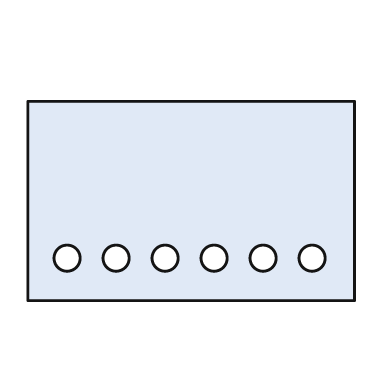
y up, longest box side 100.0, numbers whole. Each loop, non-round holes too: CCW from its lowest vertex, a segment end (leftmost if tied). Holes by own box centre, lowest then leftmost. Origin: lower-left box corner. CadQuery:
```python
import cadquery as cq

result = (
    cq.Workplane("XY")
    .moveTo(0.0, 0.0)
    .lineTo(100.0, 0.0)
    .lineTo(100.0, 61.0)
    .lineTo(0.0, 61.0)
    .close()
    .moveTo(12.0, 13.0)
    .circle(4.0)
    .moveTo(27.0, 13.0)
    .circle(4.0)
    .moveTo(42.0, 13.0)
    .circle(4.0)
    .moveTo(57.0, 13.0)
    .circle(4.0)
    .moveTo(72.0, 13.0)
    .circle(4.0)
    .moveTo(87.0, 13.0)
    .circle(4.0)
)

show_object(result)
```